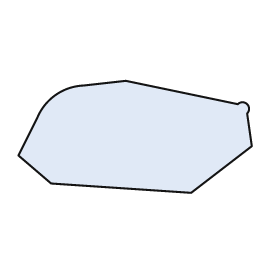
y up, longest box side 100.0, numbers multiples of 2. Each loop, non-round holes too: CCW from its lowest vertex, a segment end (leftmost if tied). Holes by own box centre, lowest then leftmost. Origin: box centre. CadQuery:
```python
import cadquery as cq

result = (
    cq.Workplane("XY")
    .moveTo(24.0, -24.0)
    .lineTo(50.0, -4.0)
    .lineTo(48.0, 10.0)
    .threePointArc((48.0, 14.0), (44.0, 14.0))
    .lineTo(-4.0, 24.0)
    .lineTo(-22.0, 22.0)
    .threePointArc((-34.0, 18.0), (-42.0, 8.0))
    .lineTo(-50.0, -8.0)
    .lineTo(-36.0, -20.0)
    .close()
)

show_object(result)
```